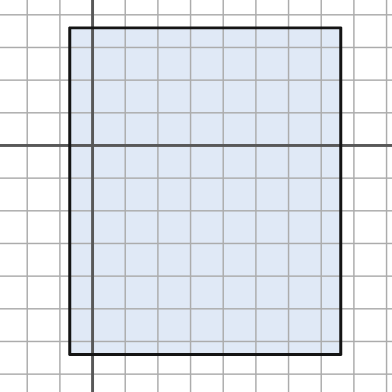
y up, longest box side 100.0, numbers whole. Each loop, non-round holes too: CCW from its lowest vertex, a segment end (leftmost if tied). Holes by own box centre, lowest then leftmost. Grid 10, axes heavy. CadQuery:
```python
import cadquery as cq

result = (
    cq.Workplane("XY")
    .moveTo(-7.0, -64.0)
    .lineTo(76.0, -64.0)
    .lineTo(76.0, 36.0)
    .lineTo(-7.0, 36.0)
    .close()
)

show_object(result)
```